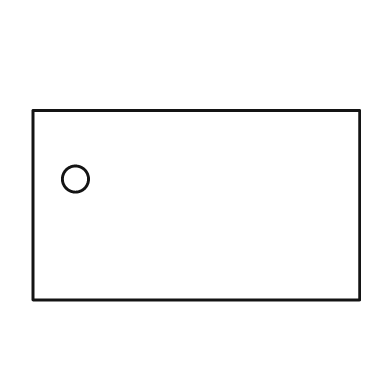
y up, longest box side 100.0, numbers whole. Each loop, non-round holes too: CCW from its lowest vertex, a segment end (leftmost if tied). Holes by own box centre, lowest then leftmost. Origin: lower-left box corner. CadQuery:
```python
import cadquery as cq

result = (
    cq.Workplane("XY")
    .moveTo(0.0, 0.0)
    .lineTo(100.0, 0.0)
    .lineTo(100.0, 58.0)
    .lineTo(0.0, 58.0)
    .close()
    .moveTo(13.0, 37.0)
    .circle(4.0)
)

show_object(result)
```